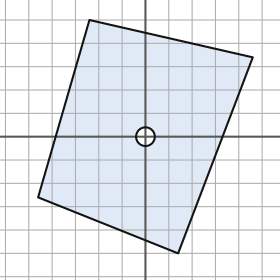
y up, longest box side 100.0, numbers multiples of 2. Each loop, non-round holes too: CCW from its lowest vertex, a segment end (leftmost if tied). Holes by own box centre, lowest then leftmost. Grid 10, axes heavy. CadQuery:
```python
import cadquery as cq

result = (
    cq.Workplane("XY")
    .moveTo(14.0, -50.0)
    .lineTo(46.0, 34.0)
    .lineTo(-24.0, 50.0)
    .lineTo(-46.0, -26.0)
    .close()
    .moveTo(0.0, 0.0)
    .circle(4.0)
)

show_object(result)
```